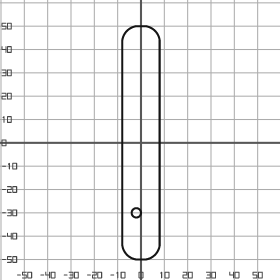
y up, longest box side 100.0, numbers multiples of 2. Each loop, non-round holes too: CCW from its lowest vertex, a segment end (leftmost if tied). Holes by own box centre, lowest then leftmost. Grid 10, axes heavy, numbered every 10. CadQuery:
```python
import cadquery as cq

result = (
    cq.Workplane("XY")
    .moveTo(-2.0, -50.0)
    .lineTo(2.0, -50.0)
    .threePointArc((6.0, -48.0), (8.0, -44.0))
    .lineTo(8.0, 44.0)
    .threePointArc((6.0, 48.0), (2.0, 50.0))
    .lineTo(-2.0, 50.0)
    .threePointArc((-6.0, 48.0), (-8.0, 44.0))
    .lineTo(-8.0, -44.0)
    .threePointArc((-6.0, -48.0), (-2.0, -50.0))
    .close()
    .moveTo(-2.0, -30.0)
    .circle(2.0)
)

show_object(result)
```